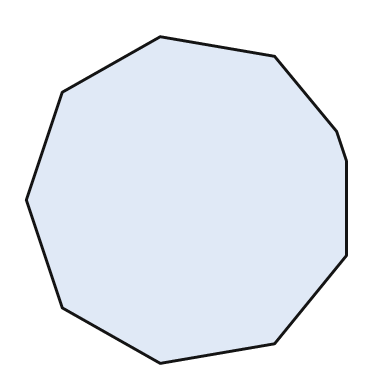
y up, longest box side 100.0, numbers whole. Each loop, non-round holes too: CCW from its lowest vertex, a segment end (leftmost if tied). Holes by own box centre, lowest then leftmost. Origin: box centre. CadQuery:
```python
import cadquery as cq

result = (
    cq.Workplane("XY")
    .moveTo(-8.0, -50.0)
    .lineTo(27.0, -44.0)
    .lineTo(49.0, -17.0)
    .lineTo(49.0, 12.0)
    .lineTo(46.0, 21.0)
    .lineTo(27.0, 44.0)
    .lineTo(-8.0, 50.0)
    .lineTo(-38.0, 33.0)
    .lineTo(-49.0, 0.0)
    .lineTo(-38.0, -33.0)
    .close()
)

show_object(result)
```